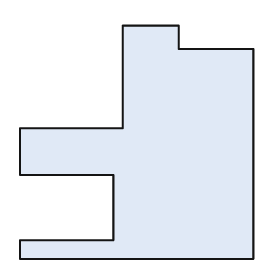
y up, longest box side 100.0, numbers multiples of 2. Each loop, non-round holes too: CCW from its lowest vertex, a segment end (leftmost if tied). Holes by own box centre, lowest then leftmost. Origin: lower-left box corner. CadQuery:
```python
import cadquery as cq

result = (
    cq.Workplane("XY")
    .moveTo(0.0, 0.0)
    .lineTo(100.0, 0.0)
    .lineTo(100.0, 90.0)
    .lineTo(68.0, 90.0)
    .lineTo(68.0, 100.0)
    .lineTo(44.0, 100.0)
    .lineTo(44.0, 56.0)
    .lineTo(0.0, 56.0)
    .lineTo(0.0, 36.0)
    .lineTo(40.0, 36.0)
    .lineTo(40.0, 8.0)
    .lineTo(0.0, 8.0)
    .close()
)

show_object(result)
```